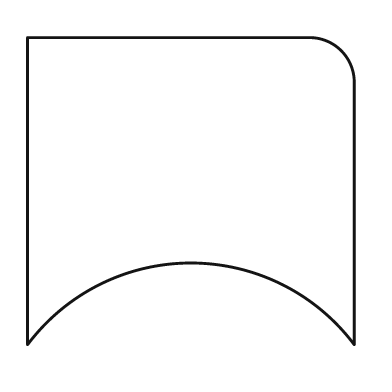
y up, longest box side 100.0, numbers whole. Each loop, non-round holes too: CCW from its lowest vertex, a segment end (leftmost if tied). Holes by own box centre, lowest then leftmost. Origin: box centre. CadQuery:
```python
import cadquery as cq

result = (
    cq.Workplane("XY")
    .moveTo(-50.0, -47.0)
    .threePointArc((0.0, -22.0), (50.0, -47.0))
    .lineTo(50.0, 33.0)
    .threePointArc((46.0, 43.0), (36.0, 47.0))
    .lineTo(-50.0, 47.0)
    .close()
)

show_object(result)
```